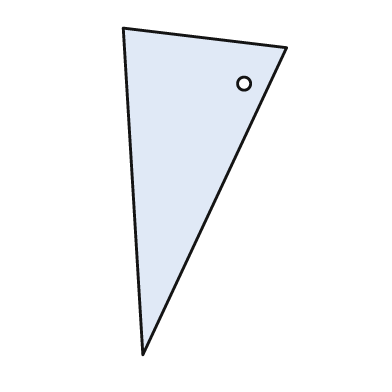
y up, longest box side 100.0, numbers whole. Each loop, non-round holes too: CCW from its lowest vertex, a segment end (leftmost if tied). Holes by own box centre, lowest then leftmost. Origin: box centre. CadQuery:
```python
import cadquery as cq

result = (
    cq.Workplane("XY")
    .moveTo(-19.0, -50.0)
    .lineTo(25.0, 44.0)
    .lineTo(-25.0, 50.0)
    .close()
    .moveTo(12.0, 33.0)
    .circle(2.0)
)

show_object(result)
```